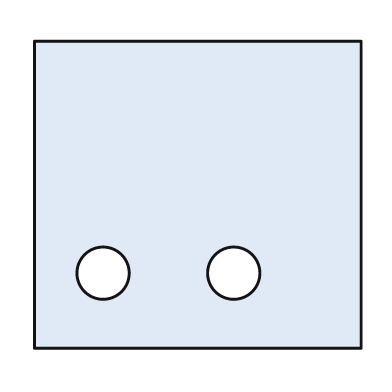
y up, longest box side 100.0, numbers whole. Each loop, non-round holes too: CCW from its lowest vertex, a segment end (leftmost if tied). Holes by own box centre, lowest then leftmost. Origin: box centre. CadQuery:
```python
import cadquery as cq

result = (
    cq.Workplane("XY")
    .moveTo(-50.0, -47.0)
    .lineTo(50.0, -47.0)
    .lineTo(50.0, 47.0)
    .lineTo(-50.0, 47.0)
    .close()
    .moveTo(-29.0, -24.0)
    .circle(8.0)
    .moveTo(11.0, -24.0)
    .circle(8.0)
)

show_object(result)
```